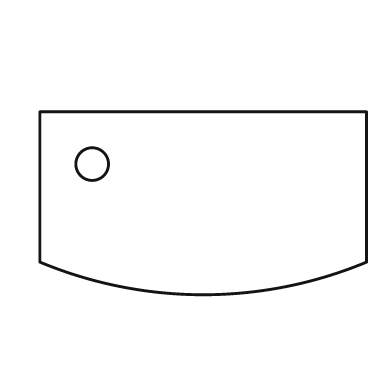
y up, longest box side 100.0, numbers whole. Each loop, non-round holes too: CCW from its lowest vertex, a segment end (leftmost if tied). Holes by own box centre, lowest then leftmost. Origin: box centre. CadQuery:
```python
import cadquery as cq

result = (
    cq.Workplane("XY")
    .moveTo(-50.0, -18.0)
    .threePointArc((0.0, -28.0), (50.0, -18.0))
    .lineTo(50.0, 28.0)
    .lineTo(-50.0, 28.0)
    .close()
    .moveTo(-34.0, 12.0)
    .circle(5.0)
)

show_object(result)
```